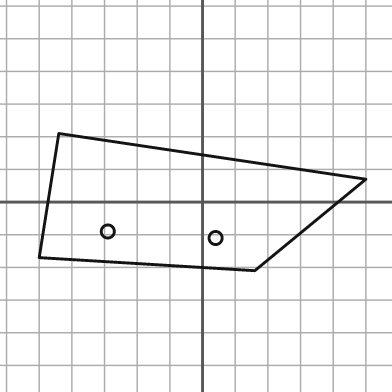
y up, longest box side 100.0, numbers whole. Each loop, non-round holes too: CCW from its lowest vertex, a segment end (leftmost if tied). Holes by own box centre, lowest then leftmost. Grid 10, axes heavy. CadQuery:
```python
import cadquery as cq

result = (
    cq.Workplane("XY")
    .moveTo(16.0, -21.0)
    .lineTo(50.0, 7.0)
    .lineTo(-44.0, 21.0)
    .lineTo(-50.0, -17.0)
    .close()
    .moveTo(4.0, -11.0)
    .circle(2.0)
    .moveTo(-29.0, -9.0)
    .circle(2.0)
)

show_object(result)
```